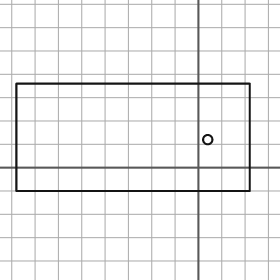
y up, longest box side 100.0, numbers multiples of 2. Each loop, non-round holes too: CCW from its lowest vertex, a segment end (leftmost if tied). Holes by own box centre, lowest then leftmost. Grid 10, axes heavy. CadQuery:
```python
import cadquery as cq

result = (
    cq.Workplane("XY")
    .moveTo(-78.0, -10.0)
    .lineTo(22.0, -10.0)
    .lineTo(22.0, 36.0)
    .lineTo(-78.0, 36.0)
    .close()
    .moveTo(4.0, 12.0)
    .circle(2.0)
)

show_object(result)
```